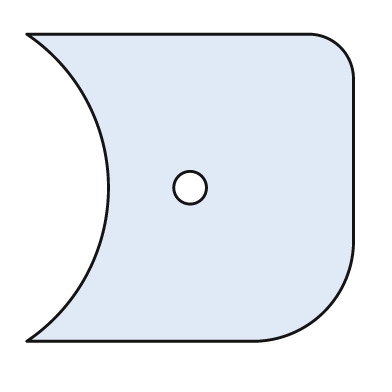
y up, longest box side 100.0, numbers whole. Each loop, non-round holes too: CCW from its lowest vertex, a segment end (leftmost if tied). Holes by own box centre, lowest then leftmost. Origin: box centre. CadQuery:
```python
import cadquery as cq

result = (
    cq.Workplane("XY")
    .moveTo(-50.0, -47.0)
    .lineTo(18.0, -47.0)
    .threePointArc((41.0, -38.0), (50.0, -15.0))
    .lineTo(50.0, 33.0)
    .threePointArc((46.0, 43.0), (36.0, 47.0))
    .lineTo(-50.0, 47.0)
    .threePointArc((-25.0, 0.0), (-50.0, -47.0))
    .close()
    .moveTo(0.0, 0.0)
    .circle(5.0)
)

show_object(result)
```